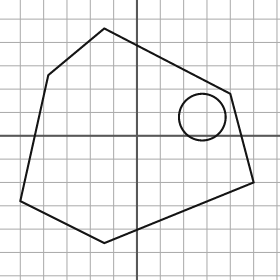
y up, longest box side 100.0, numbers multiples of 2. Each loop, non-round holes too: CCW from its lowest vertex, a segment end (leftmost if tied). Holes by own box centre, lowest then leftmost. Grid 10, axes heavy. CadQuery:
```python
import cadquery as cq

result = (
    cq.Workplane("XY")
    .moveTo(-14.0, -46.0)
    .lineTo(50.0, -20.0)
    .lineTo(40.0, 18.0)
    .lineTo(-14.0, 46.0)
    .lineTo(-38.0, 26.0)
    .lineTo(-50.0, -28.0)
    .close()
    .moveTo(28.0, 8.0)
    .circle(10.0)
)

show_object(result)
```